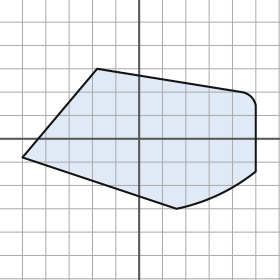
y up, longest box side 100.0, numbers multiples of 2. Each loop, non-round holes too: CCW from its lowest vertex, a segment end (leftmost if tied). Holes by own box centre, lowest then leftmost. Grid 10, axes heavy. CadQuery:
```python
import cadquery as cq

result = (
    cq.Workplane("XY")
    .moveTo(16.0, -30.0)
    .threePointArc((34.0, -24.0), (50.0, -14.0))
    .lineTo(50.0, 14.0)
    .threePointArc((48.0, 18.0), (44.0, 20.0))
    .lineTo(-18.0, 30.0)
    .lineTo(-50.0, -8.0)
    .close()
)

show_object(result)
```